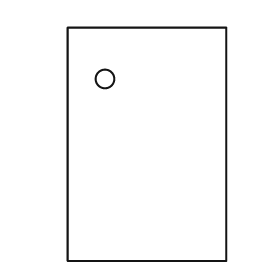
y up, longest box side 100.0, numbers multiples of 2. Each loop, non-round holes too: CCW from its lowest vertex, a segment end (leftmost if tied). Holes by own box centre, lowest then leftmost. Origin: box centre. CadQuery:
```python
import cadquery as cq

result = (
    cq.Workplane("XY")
    .moveTo(-34.0, -50.0)
    .lineTo(34.0, -50.0)
    .lineTo(34.0, 50.0)
    .lineTo(-34.0, 50.0)
    .close()
    .moveTo(-18.0, 28.0)
    .circle(4.0)
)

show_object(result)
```